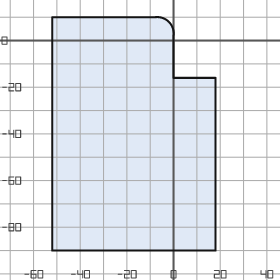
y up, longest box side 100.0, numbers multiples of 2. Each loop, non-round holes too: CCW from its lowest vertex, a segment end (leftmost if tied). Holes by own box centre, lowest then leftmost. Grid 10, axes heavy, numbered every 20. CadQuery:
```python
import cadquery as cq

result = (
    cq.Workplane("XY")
    .moveTo(-52.0, -90.0)
    .lineTo(18.0, -90.0)
    .lineTo(18.0, -16.0)
    .lineTo(0.0, -16.0)
    .lineTo(0.0, 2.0)
    .threePointArc((-2.0, 8.0), (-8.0, 10.0))
    .lineTo(-52.0, 10.0)
    .close()
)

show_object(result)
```